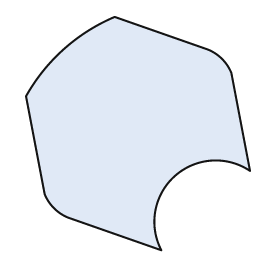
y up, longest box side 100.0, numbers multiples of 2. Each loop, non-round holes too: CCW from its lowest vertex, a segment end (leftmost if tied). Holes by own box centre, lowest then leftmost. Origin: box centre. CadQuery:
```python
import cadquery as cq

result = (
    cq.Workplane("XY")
    .moveTo(10.0, -50.0)
    .threePointArc((16.0, -18.0), (48.0, -16.0))
    .lineTo(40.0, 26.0)
    .threePointArc((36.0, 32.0), (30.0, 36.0))
    .lineTo(-10.0, 50.0)
    .threePointArc((-32.0, 36.0), (-48.0, 16.0))
    .lineTo(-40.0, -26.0)
    .threePointArc((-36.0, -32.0), (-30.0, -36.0))
    .close()
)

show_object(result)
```